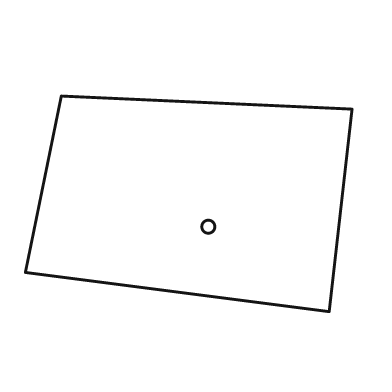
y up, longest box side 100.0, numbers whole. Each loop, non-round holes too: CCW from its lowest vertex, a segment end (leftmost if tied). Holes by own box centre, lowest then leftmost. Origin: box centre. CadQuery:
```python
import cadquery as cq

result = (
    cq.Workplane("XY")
    .moveTo(43.0, -33.0)
    .lineTo(50.0, 29.0)
    .lineTo(-39.0, 33.0)
    .lineTo(-50.0, -21.0)
    .close()
    .moveTo(6.0, -7.0)
    .circle(2.0)
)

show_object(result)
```